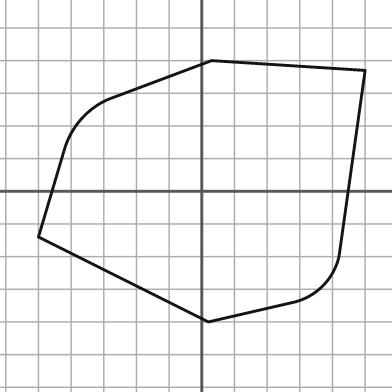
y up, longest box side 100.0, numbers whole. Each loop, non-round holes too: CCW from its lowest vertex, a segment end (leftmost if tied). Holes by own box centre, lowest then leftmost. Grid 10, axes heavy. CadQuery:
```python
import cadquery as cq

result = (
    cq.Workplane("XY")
    .moveTo(2.0, -40.0)
    .lineTo(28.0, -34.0)
    .threePointArc((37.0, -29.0), (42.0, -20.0))
    .lineTo(50.0, 37.0)
    .lineTo(3.0, 40.0)
    .lineTo(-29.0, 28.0)
    .threePointArc((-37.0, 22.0), (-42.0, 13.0))
    .lineTo(-50.0, -14.0)
    .close()
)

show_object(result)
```